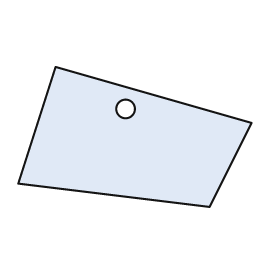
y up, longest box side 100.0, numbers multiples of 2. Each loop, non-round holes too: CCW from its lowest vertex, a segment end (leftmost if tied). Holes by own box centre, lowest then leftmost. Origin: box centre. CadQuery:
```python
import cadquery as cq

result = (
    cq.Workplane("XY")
    .moveTo(32.0, -30.0)
    .lineTo(50.0, 6.0)
    .lineTo(-34.0, 30.0)
    .lineTo(-50.0, -20.0)
    .close()
    .moveTo(-4.0, 12.0)
    .circle(4.0)
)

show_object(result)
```